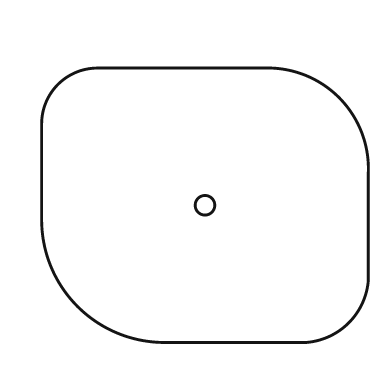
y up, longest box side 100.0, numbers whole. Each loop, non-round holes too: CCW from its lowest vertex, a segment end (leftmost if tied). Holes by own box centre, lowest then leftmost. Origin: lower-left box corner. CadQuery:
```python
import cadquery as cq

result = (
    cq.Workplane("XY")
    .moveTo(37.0, 0.0)
    .lineTo(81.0, 0.0)
    .threePointArc((94.0, 6.0), (100.0, 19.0))
    .lineTo(100.0, 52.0)
    .threePointArc((91.0, 75.0), (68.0, 84.0))
    .lineTo(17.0, 84.0)
    .threePointArc((5.0, 79.0), (0.0, 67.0))
    .lineTo(0.0, 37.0)
    .threePointArc((11.0, 11.0), (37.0, 0.0))
    .close()
    .moveTo(50.0, 42.0)
    .circle(3.0)
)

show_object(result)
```